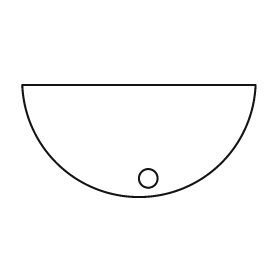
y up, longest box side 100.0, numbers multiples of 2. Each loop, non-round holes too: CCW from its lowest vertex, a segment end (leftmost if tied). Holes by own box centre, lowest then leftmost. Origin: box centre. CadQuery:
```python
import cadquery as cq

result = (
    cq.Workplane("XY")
    .moveTo(-50.0, 24.0)
    .threePointArc((0.0, -24.0), (50.0, 24.0))
    .close()
    .moveTo(4.0, -16.0)
    .circle(4.0)
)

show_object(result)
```